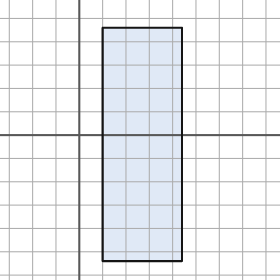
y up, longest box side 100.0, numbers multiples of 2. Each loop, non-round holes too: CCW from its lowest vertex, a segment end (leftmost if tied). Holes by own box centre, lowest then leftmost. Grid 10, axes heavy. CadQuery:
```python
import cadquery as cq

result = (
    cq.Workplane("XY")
    .moveTo(10.0, -54.0)
    .lineTo(44.0, -54.0)
    .lineTo(44.0, 46.0)
    .lineTo(10.0, 46.0)
    .close()
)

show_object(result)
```